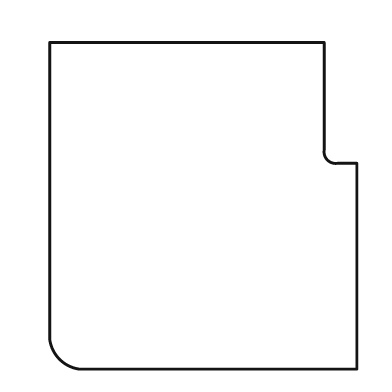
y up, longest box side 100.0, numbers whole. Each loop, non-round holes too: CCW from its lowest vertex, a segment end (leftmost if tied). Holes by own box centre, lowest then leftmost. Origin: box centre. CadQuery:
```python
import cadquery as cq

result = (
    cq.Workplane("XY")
    .moveTo(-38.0, -50.0)
    .lineTo(47.0, -50.0)
    .lineTo(47.0, 13.0)
    .lineTo(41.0, 13.0)
    .threePointArc((38.0, 14.0), (37.0, 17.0))
    .lineTo(37.0, 50.0)
    .lineTo(-47.0, 50.0)
    .lineTo(-47.0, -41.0)
    .threePointArc((-44.0, -47.0), (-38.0, -50.0))
    .close()
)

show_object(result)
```